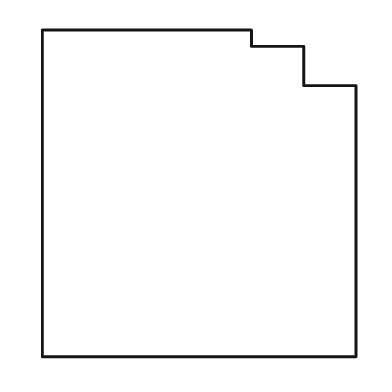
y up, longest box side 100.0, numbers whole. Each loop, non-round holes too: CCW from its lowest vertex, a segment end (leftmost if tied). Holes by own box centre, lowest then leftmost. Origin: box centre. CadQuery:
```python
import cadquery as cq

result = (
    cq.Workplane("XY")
    .moveTo(-48.0, -50.0)
    .lineTo(48.0, -50.0)
    .lineTo(48.0, 33.0)
    .lineTo(32.0, 33.0)
    .lineTo(32.0, 45.0)
    .lineTo(16.0, 45.0)
    .lineTo(16.0, 50.0)
    .lineTo(-48.0, 50.0)
    .close()
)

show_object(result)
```